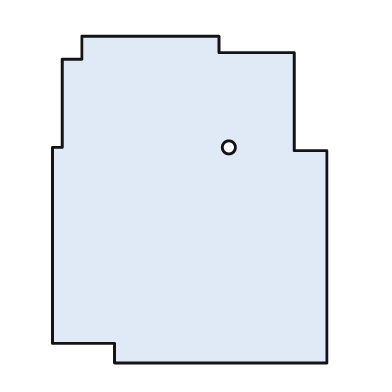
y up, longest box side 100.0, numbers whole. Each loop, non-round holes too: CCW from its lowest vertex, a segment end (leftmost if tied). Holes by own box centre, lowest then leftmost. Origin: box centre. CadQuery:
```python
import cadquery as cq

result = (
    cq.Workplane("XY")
    .moveTo(-23.0, -50.0)
    .lineTo(42.0, -50.0)
    .lineTo(42.0, 15.0)
    .lineTo(32.0, 15.0)
    .lineTo(32.0, 45.0)
    .lineTo(9.0, 45.0)
    .lineTo(9.0, 50.0)
    .lineTo(-33.0, 50.0)
    .lineTo(-33.0, 43.0)
    .lineTo(-39.0, 43.0)
    .lineTo(-39.0, 16.0)
    .lineTo(-42.0, 16.0)
    .lineTo(-42.0, -44.0)
    .lineTo(-23.0, -44.0)
    .close()
    .moveTo(12.0, 16.0)
    .circle(2.0)
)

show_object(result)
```